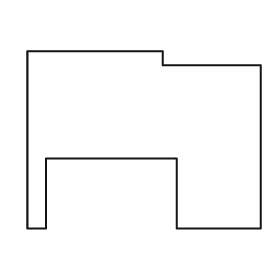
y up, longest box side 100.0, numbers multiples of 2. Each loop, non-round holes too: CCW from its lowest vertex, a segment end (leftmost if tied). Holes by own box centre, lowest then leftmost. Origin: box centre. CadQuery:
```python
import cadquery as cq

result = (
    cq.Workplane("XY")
    .moveTo(-50.0, -38.0)
    .lineTo(-42.0, -38.0)
    .lineTo(-42.0, -8.0)
    .lineTo(14.0, -8.0)
    .lineTo(14.0, -38.0)
    .lineTo(50.0, -38.0)
    .lineTo(50.0, 32.0)
    .lineTo(8.0, 32.0)
    .lineTo(8.0, 38.0)
    .lineTo(-50.0, 38.0)
    .close()
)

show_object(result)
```